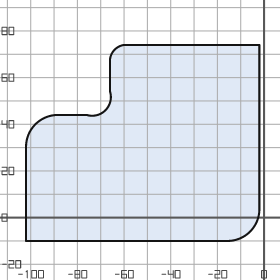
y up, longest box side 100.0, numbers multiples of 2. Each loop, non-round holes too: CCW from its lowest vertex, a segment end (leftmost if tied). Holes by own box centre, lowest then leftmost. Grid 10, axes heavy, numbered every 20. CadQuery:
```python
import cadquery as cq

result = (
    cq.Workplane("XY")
    .moveTo(-102.0, -10.0)
    .lineTo(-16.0, -10.0)
    .threePointArc((-6.0, -6.0), (-2.0, 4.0))
    .lineTo(-2.0, 74.0)
    .lineTo(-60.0, 74.0)
    .threePointArc((-64.0, 72.0), (-66.0, 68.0))
    .lineTo(-66.0, 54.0)
    .threePointArc((-68.0, 46.0), (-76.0, 44.0))
    .lineTo(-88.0, 44.0)
    .threePointArc((-98.0, 40.0), (-102.0, 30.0))
    .close()
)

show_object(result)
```